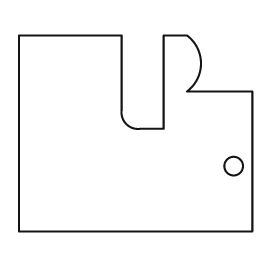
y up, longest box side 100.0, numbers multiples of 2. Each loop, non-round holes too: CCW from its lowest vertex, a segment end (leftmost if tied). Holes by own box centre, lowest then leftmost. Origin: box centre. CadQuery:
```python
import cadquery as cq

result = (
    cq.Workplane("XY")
    .moveTo(-50.0, -42.0)
    .lineTo(50.0, -42.0)
    .lineTo(50.0, 18.0)
    .lineTo(22.0, 18.0)
    .threePointArc((28.0, 30.0), (22.0, 42.0))
    .lineTo(12.0, 42.0)
    .lineTo(12.0, 2.0)
    .lineTo(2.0, 2.0)
    .threePointArc((-4.0, 4.0), (-6.0, 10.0))
    .lineTo(-6.0, 42.0)
    .lineTo(-50.0, 42.0)
    .close()
    .moveTo(42.0, -14.0)
    .circle(4.0)
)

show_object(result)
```